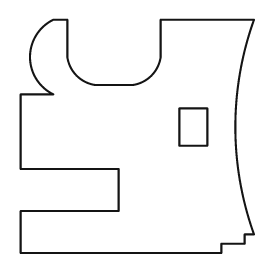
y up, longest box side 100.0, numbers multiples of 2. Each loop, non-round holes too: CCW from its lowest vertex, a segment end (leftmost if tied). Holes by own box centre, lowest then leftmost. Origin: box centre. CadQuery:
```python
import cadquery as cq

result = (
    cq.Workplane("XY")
    .moveTo(-50.0, -50.0)
    .lineTo(36.0, -50.0)
    .lineTo(36.0, -46.0)
    .lineTo(46.0, -46.0)
    .lineTo(46.0, -42.0)
    .lineTo(50.0, -42.0)
    .threePointArc((42.0, 4.0), (50.0, 50.0))
    .lineTo(10.0, 50.0)
    .lineTo(10.0, 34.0)
    .threePointArc((6.0, 26.0), (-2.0, 22.0))
    .lineTo(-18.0, 22.0)
    .threePointArc((-26.0, 26.0), (-30.0, 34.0))
    .lineTo(-30.0, 50.0)
    .lineTo(-36.0, 50.0)
    .threePointArc((-46.0, 34.0), (-36.0, 18.0))
    .lineTo(-50.0, 18.0)
    .lineTo(-50.0, -14.0)
    .lineTo(-8.0, -14.0)
    .lineTo(-8.0, -32.0)
    .lineTo(-50.0, -32.0)
    .close()
    .moveTo(18.0, -4.0)
    .lineTo(30.0, -4.0)
    .lineTo(30.0, 12.0)
    .lineTo(18.0, 12.0)
    .close()
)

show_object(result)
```